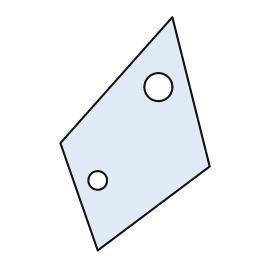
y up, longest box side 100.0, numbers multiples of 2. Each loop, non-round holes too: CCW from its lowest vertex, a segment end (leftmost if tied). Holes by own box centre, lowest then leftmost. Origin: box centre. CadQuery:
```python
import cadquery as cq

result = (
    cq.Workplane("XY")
    .moveTo(-16.0, -50.0)
    .lineTo(32.0, -14.0)
    .lineTo(16.0, 50.0)
    .lineTo(-32.0, -4.0)
    .close()
    .moveTo(-16.0, -20.0)
    .circle(4.0)
    .moveTo(10.0, 20.0)
    .circle(6.0)
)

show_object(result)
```